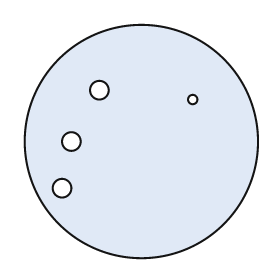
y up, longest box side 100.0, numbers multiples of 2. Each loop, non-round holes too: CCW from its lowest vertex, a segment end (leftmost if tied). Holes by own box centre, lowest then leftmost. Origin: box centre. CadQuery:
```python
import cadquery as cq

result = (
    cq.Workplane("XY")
    .moveTo(0.0, 0.0)
    .circle(50.0)
    .moveTo(-34.0, -20.0)
    .circle(4.0)
    .moveTo(-30.0, 0.0)
    .circle(4.0)
    .moveTo(22.0, 18.0)
    .circle(2.0)
    .moveTo(-18.0, 22.0)
    .circle(4.0)
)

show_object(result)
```